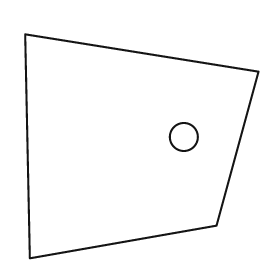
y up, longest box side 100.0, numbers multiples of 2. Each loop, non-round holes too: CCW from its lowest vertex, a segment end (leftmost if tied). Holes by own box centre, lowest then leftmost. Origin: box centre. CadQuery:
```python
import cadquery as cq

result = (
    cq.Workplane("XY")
    .moveTo(-48.0, -48.0)
    .lineTo(32.0, -34.0)
    .lineTo(50.0, 32.0)
    .lineTo(-50.0, 48.0)
    .close()
    .moveTo(18.0, 4.0)
    .circle(6.0)
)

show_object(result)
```